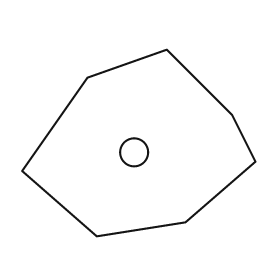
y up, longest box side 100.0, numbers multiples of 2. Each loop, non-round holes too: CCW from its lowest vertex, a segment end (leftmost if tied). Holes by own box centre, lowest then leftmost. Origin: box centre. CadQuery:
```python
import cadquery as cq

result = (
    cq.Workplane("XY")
    .moveTo(-18.0, -40.0)
    .lineTo(20.0, -34.0)
    .lineTo(50.0, -8.0)
    .lineTo(40.0, 12.0)
    .lineTo(12.0, 40.0)
    .lineTo(-22.0, 28.0)
    .lineTo(-50.0, -12.0)
    .close()
    .moveTo(-2.0, -4.0)
    .circle(6.0)
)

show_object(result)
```